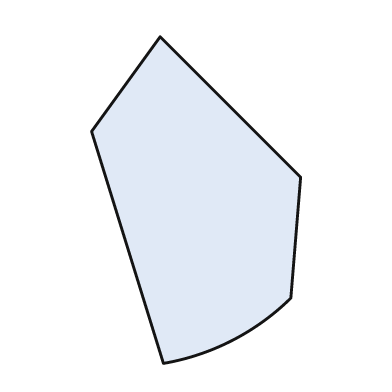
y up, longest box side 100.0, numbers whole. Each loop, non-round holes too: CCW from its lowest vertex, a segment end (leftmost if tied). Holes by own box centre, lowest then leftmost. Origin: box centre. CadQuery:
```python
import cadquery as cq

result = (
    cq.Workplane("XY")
    .moveTo(-10.0, -50.0)
    .threePointArc((11.0, -43.0), (29.0, -30.0))
    .lineTo(32.0, 7.0)
    .lineTo(-11.0, 50.0)
    .lineTo(-32.0, 21.0)
    .close()
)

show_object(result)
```